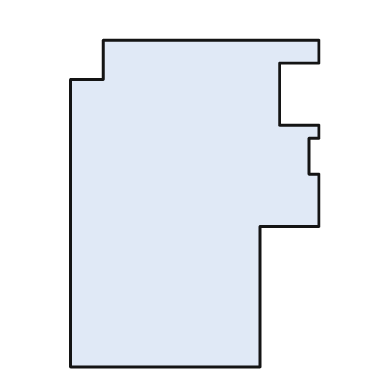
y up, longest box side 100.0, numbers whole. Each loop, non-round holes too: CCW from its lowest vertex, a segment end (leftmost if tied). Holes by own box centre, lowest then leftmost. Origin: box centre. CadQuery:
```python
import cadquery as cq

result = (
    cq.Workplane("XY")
    .moveTo(-38.0, -50.0)
    .lineTo(20.0, -50.0)
    .lineTo(20.0, -7.0)
    .lineTo(38.0, -7.0)
    .lineTo(38.0, 9.0)
    .lineTo(35.0, 9.0)
    .lineTo(35.0, 20.0)
    .lineTo(38.0, 20.0)
    .lineTo(38.0, 24.0)
    .lineTo(26.0, 24.0)
    .lineTo(26.0, 43.0)
    .lineTo(38.0, 43.0)
    .lineTo(38.0, 50.0)
    .lineTo(-28.0, 50.0)
    .lineTo(-28.0, 38.0)
    .lineTo(-38.0, 38.0)
    .close()
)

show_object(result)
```